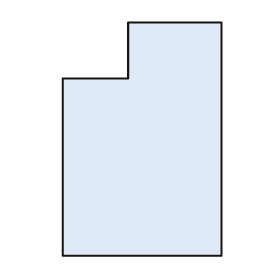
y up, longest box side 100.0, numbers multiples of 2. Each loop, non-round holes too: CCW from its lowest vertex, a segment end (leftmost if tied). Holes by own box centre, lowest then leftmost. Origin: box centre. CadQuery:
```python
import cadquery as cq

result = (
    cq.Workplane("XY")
    .moveTo(-34.0, -50.0)
    .lineTo(34.0, -50.0)
    .lineTo(34.0, 50.0)
    .lineTo(-6.0, 50.0)
    .lineTo(-6.0, 26.0)
    .lineTo(-34.0, 26.0)
    .close()
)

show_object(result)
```